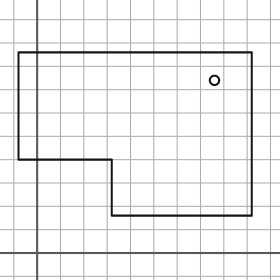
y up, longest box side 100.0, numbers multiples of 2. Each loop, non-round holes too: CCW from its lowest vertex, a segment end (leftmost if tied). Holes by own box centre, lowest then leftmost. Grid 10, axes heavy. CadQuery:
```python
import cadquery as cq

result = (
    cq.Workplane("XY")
    .moveTo(32.0, 16.0)
    .lineTo(92.0, 16.0)
    .lineTo(92.0, 86.0)
    .lineTo(-8.0, 86.0)
    .lineTo(-8.0, 40.0)
    .lineTo(32.0, 40.0)
    .close()
    .moveTo(76.0, 74.0)
    .circle(2.0)
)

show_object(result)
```